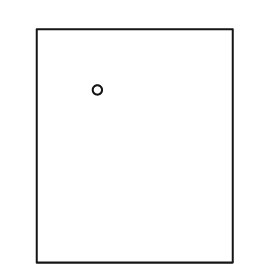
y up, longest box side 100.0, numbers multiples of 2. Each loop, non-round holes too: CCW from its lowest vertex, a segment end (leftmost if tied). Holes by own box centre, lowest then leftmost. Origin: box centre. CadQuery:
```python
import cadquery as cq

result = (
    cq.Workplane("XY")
    .moveTo(-42.0, -50.0)
    .lineTo(42.0, -50.0)
    .lineTo(42.0, 50.0)
    .lineTo(-42.0, 50.0)
    .close()
    .moveTo(-16.0, 24.0)
    .circle(2.0)
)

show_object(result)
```